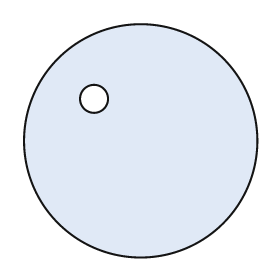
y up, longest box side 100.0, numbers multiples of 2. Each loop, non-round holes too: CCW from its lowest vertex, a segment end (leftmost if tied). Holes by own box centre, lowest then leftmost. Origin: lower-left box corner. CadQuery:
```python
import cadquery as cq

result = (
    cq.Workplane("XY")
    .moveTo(50.0, 50.0)
    .circle(50.0)
    .moveTo(30.0, 68.0)
    .circle(6.0)
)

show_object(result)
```